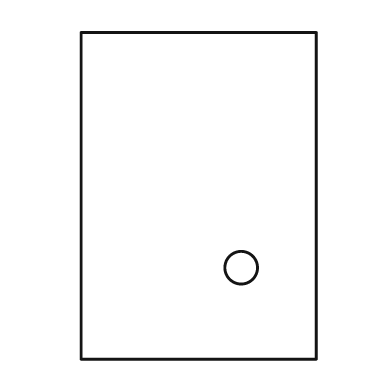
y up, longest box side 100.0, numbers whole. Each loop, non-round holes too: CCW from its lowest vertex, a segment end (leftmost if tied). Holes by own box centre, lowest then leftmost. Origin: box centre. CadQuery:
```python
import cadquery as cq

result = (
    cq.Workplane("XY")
    .moveTo(-36.0, -50.0)
    .lineTo(36.0, -50.0)
    .lineTo(36.0, 50.0)
    .lineTo(-36.0, 50.0)
    .close()
    .moveTo(13.0, -22.0)
    .circle(5.0)
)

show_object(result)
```